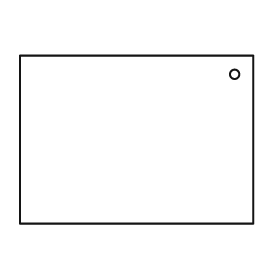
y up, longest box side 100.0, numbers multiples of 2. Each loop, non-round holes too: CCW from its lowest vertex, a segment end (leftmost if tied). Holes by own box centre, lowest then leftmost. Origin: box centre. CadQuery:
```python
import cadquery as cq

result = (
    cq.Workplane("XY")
    .moveTo(-50.0, -36.0)
    .lineTo(50.0, -36.0)
    .lineTo(50.0, 36.0)
    .lineTo(-50.0, 36.0)
    .close()
    .moveTo(42.0, 28.0)
    .circle(2.0)
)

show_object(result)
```